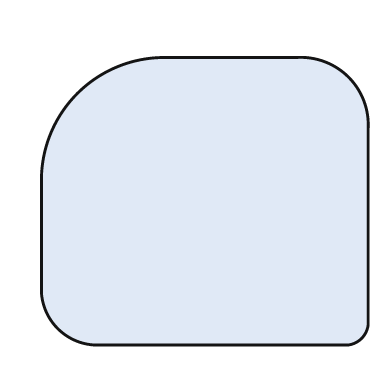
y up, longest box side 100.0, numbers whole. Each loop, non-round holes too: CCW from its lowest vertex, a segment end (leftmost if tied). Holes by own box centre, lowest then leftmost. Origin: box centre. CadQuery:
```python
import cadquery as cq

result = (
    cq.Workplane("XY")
    .moveTo(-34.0, -44.0)
    .lineTo(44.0, -44.0)
    .threePointArc((48.0, -42.0), (50.0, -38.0))
    .lineTo(50.0, 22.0)
    .threePointArc((44.0, 38.0), (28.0, 44.0))
    .lineTo(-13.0, 44.0)
    .threePointArc((-39.0, 33.0), (-50.0, 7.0))
    .lineTo(-50.0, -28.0)
    .threePointArc((-45.0, -39.0), (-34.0, -44.0))
    .close()
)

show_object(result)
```